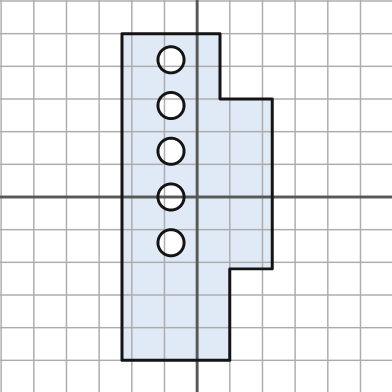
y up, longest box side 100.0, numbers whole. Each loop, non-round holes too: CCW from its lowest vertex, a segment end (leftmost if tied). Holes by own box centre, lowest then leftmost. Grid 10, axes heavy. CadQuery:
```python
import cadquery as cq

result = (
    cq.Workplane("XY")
    .moveTo(-23.0, -50.0)
    .lineTo(10.0, -50.0)
    .lineTo(10.0, -22.0)
    .lineTo(23.0, -22.0)
    .lineTo(23.0, 30.0)
    .lineTo(7.0, 30.0)
    .lineTo(7.0, 50.0)
    .lineTo(-23.0, 50.0)
    .close()
    .moveTo(-8.0, -14.0)
    .circle(4.0)
    .moveTo(-8.0, 0.0)
    .circle(4.0)
    .moveTo(-8.0, 14.0)
    .circle(4.0)
    .moveTo(-8.0, 28.0)
    .circle(4.0)
    .moveTo(-8.0, 42.0)
    .circle(4.0)
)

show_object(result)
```